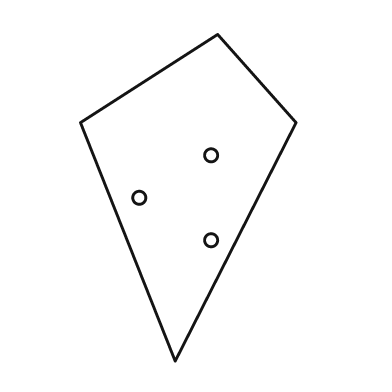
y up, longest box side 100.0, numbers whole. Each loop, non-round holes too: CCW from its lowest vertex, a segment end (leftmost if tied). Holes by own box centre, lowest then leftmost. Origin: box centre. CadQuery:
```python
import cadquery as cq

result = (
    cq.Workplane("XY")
    .moveTo(-4.0, -50.0)
    .lineTo(33.0, 23.0)
    .lineTo(9.0, 50.0)
    .lineTo(-33.0, 23.0)
    .close()
    .moveTo(7.0, -13.0)
    .circle(2.0)
    .moveTo(-15.0, 0.0)
    .circle(2.0)
    .moveTo(7.0, 13.0)
    .circle(2.0)
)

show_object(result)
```